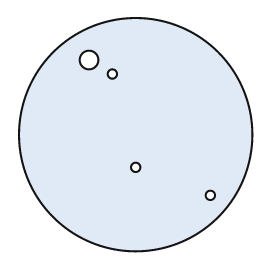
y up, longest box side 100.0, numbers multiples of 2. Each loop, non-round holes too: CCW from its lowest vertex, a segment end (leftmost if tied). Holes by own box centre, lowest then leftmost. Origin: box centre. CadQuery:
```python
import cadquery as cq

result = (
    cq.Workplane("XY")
    .moveTo(0.0, 0.0)
    .circle(50.0)
    .moveTo(32.0, -26.0)
    .circle(2.0)
    .moveTo(0.0, -14.0)
    .circle(2.0)
    .moveTo(-10.0, 26.0)
    .circle(2.0)
    .moveTo(-20.0, 32.0)
    .circle(4.0)
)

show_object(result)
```